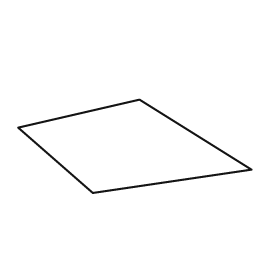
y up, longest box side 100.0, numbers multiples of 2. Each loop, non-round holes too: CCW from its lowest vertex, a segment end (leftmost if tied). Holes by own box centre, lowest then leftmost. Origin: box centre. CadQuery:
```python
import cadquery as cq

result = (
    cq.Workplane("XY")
    .moveTo(-18.0, -20.0)
    .lineTo(50.0, -10.0)
    .lineTo(2.0, 20.0)
    .lineTo(-50.0, 8.0)
    .close()
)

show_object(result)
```